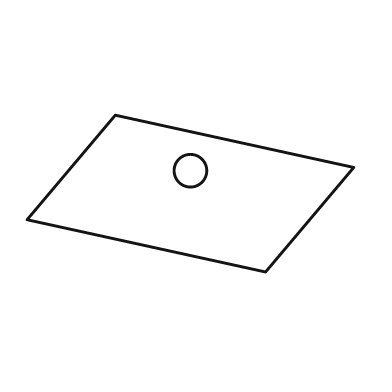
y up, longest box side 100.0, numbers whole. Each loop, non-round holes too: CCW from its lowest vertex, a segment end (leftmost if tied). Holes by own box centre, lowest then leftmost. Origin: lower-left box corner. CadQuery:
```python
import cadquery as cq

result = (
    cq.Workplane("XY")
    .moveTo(73.0, 0.0)
    .lineTo(100.0, 32.0)
    .lineTo(27.0, 48.0)
    .lineTo(0.0, 16.0)
    .close()
    .moveTo(50.0, 31.0)
    .circle(5.0)
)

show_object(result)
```